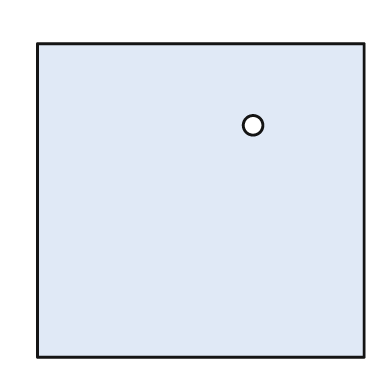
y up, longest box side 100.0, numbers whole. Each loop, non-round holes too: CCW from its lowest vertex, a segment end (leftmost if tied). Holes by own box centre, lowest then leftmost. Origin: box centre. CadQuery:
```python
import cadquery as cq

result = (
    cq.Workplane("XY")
    .moveTo(-50.0, -48.0)
    .lineTo(50.0, -48.0)
    .lineTo(50.0, 48.0)
    .lineTo(-50.0, 48.0)
    .close()
    .moveTo(16.0, 23.0)
    .circle(3.0)
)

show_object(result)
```